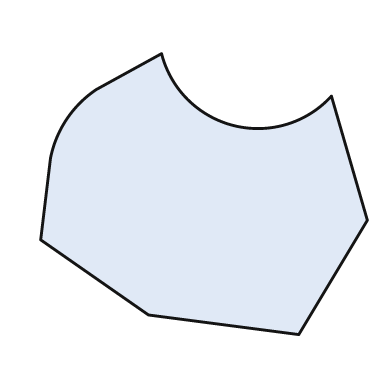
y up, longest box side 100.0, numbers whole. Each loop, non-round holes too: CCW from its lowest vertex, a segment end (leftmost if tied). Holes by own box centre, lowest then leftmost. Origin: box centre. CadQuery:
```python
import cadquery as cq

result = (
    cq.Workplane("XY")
    .moveTo(29.0, -43.0)
    .lineTo(50.0, -8.0)
    .lineTo(39.0, 30.0)
    .threePointArc((9.0, 21.0), (-13.0, 43.0))
    .lineTo(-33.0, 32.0)
    .threePointArc((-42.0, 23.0), (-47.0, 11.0))
    .lineTo(-50.0, -14.0)
    .lineTo(-17.0, -37.0)
    .close()
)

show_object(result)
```